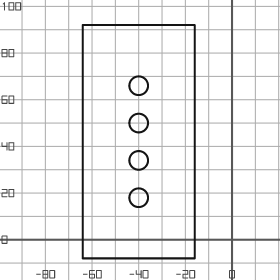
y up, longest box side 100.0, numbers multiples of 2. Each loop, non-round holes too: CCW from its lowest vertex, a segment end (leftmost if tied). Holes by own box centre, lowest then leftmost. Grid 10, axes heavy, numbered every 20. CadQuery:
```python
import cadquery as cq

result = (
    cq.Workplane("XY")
    .moveTo(-64.0, -8.0)
    .lineTo(-16.0, -8.0)
    .lineTo(-16.0, 92.0)
    .lineTo(-64.0, 92.0)
    .close()
    .moveTo(-40.0, 18.0)
    .circle(4.0)
    .moveTo(-40.0, 34.0)
    .circle(4.0)
    .moveTo(-40.0, 50.0)
    .circle(4.0)
    .moveTo(-40.0, 66.0)
    .circle(4.0)
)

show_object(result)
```